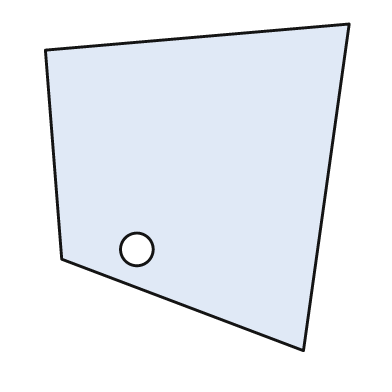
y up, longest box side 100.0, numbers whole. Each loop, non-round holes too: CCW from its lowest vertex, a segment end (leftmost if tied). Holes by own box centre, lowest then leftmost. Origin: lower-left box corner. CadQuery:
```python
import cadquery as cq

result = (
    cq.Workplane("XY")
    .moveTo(79.0, 0.0)
    .lineTo(93.0, 100.0)
    .lineTo(0.0, 92.0)
    .lineTo(5.0, 28.0)
    .close()
    .moveTo(28.0, 31.0)
    .circle(5.0)
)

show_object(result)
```